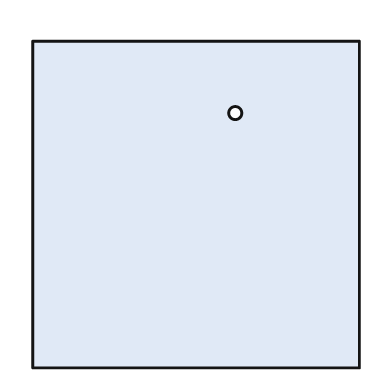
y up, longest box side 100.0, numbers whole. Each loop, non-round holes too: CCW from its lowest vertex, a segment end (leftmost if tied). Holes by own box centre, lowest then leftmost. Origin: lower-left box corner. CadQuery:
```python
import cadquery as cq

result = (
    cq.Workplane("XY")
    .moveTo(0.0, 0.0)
    .lineTo(100.0, 0.0)
    .lineTo(100.0, 100.0)
    .lineTo(0.0, 100.0)
    .close()
    .moveTo(62.0, 78.0)
    .circle(2.0)
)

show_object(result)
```